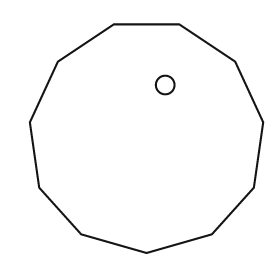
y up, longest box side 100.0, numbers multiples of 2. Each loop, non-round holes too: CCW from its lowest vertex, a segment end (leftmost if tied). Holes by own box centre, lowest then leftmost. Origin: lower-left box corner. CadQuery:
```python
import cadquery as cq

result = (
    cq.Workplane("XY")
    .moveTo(50.0, 0.0)
    .lineTo(78.0, 8.0)
    .lineTo(96.0, 28.0)
    .lineTo(100.0, 56.0)
    .lineTo(88.0, 82.0)
    .lineTo(64.0, 98.0)
    .lineTo(36.0, 98.0)
    .lineTo(12.0, 82.0)
    .lineTo(0.0, 56.0)
    .lineTo(4.0, 28.0)
    .lineTo(22.0, 8.0)
    .close()
    .moveTo(58.0, 72.0)
    .circle(4.0)
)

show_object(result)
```